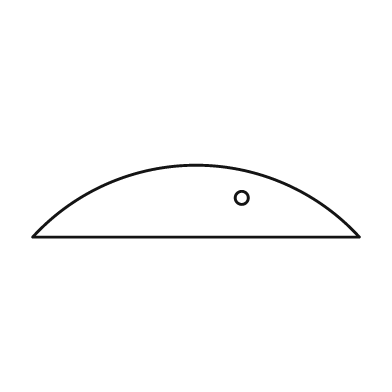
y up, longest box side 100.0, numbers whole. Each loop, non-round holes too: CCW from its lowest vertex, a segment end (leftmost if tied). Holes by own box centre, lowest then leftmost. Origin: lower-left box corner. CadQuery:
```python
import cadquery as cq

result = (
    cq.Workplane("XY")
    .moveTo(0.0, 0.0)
    .lineTo(100.0, 0.0)
    .threePointArc((50.0, 22.0), (0.0, 0.0))
    .close()
    .moveTo(64.0, 12.0)
    .circle(2.0)
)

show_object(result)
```